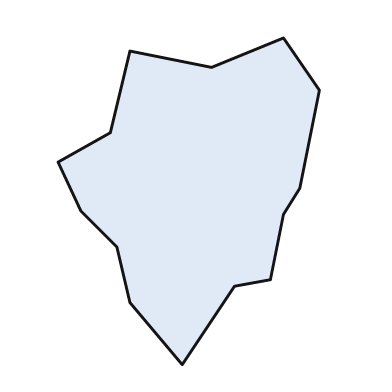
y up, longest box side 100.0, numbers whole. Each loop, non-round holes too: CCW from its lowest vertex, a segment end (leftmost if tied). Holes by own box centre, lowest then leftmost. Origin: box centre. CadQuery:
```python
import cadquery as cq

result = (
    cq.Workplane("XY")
    .moveTo(-2.0, -50.0)
    .lineTo(14.0, -26.0)
    .lineTo(25.0, -24.0)
    .lineTo(29.0, -4.0)
    .lineTo(34.0, 4.0)
    .lineTo(40.0, 34.0)
    .lineTo(29.0, 50.0)
    .lineTo(7.0, 41.0)
    .lineTo(-18.0, 46.0)
    .lineTo(-24.0, 21.0)
    .lineTo(-40.0, 12.0)
    .lineTo(-33.0, -3.0)
    .lineTo(-22.0, -14.0)
    .lineTo(-18.0, -31.0)
    .close()
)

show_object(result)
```